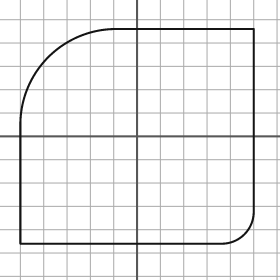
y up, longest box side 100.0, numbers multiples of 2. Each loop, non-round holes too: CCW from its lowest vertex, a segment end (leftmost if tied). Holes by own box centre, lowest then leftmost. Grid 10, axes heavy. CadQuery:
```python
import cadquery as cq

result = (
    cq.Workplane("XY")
    .moveTo(-50.0, -46.0)
    .lineTo(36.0, -46.0)
    .threePointArc((46.0, -42.0), (50.0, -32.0))
    .lineTo(50.0, 46.0)
    .lineTo(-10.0, 46.0)
    .threePointArc((-38.0, 34.0), (-50.0, 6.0))
    .close()
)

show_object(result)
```